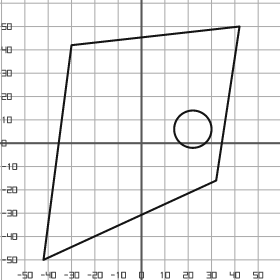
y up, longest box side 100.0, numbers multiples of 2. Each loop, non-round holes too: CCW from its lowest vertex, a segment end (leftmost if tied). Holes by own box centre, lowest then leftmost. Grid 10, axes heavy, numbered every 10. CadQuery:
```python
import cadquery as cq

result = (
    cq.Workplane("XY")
    .moveTo(-42.0, -50.0)
    .lineTo(32.0, -16.0)
    .lineTo(42.0, 50.0)
    .lineTo(-30.0, 42.0)
    .close()
    .moveTo(22.0, 6.0)
    .circle(8.0)
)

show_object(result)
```